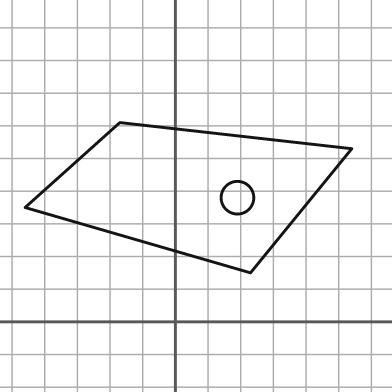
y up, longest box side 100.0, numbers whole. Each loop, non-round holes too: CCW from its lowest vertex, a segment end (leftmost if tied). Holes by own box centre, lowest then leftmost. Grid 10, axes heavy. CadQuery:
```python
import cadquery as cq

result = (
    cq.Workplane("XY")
    .moveTo(23.0, 15.0)
    .lineTo(54.0, 53.0)
    .lineTo(-17.0, 61.0)
    .lineTo(-46.0, 35.0)
    .close()
    .moveTo(19.0, 38.0)
    .circle(5.0)
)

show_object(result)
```